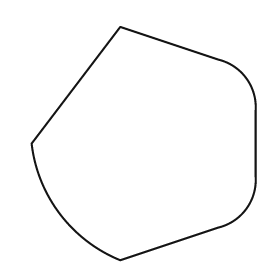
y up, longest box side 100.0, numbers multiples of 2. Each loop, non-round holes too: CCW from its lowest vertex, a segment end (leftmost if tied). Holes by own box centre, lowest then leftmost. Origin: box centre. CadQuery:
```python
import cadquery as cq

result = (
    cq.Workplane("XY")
    .moveTo(-10.0, -50.0)
    .lineTo(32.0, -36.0)
    .threePointArc((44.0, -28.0), (48.0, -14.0))
    .lineTo(48.0, 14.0)
    .threePointArc((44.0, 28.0), (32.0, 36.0))
    .lineTo(-10.0, 50.0)
    .lineTo(-48.0, 0.0)
    .threePointArc((-36.0, -30.0), (-10.0, -50.0))
    .close()
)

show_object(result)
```